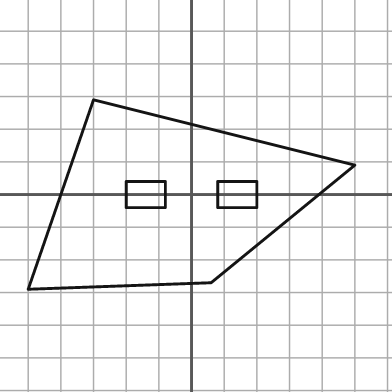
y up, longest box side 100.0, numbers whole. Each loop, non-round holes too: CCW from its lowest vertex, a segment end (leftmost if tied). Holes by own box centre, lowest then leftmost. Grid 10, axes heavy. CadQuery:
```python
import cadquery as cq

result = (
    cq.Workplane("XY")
    .moveTo(-50.0, -29.0)
    .lineTo(6.0, -27.0)
    .lineTo(50.0, 9.0)
    .lineTo(-30.0, 29.0)
    .close()
    .moveTo(-20.0, -4.0)
    .lineTo(-8.0, -4.0)
    .lineTo(-8.0, 4.0)
    .lineTo(-20.0, 4.0)
    .close()
    .moveTo(8.0, -4.0)
    .lineTo(20.0, -4.0)
    .lineTo(20.0, 4.0)
    .lineTo(8.0, 4.0)
    .close()
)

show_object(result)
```